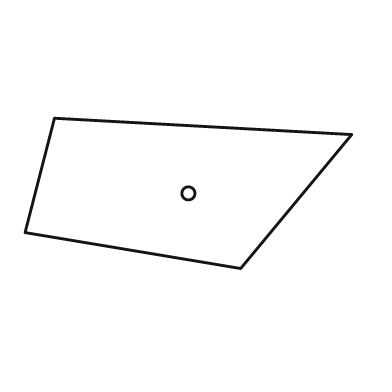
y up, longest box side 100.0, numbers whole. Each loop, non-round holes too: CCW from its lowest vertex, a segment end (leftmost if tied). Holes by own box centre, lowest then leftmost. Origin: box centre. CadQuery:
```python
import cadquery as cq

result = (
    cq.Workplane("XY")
    .moveTo(16.0, -23.0)
    .lineTo(50.0, 18.0)
    .lineTo(-41.0, 23.0)
    .lineTo(-50.0, -12.0)
    .close()
    .moveTo(0.0, 0.0)
    .circle(2.0)
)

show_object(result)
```